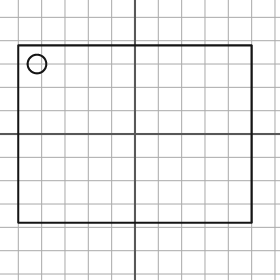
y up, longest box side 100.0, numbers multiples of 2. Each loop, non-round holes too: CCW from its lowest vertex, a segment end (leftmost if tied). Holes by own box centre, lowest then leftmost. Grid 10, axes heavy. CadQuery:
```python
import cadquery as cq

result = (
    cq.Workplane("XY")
    .moveTo(-50.0, -38.0)
    .lineTo(50.0, -38.0)
    .lineTo(50.0, 38.0)
    .lineTo(-50.0, 38.0)
    .close()
    .moveTo(-42.0, 30.0)
    .circle(4.0)
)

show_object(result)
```